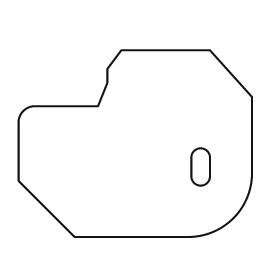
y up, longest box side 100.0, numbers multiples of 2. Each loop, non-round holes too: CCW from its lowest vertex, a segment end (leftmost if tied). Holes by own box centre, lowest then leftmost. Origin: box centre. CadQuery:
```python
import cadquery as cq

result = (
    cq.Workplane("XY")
    .moveTo(-26.0, -40.0)
    .lineTo(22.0, -40.0)
    .threePointArc((42.0, -32.0), (50.0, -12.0))
    .lineTo(50.0, 20.0)
    .lineTo(32.0, 40.0)
    .lineTo(-6.0, 40.0)
    .lineTo(-12.0, 32.0)
    .lineTo(-12.0, 26.0)
    .lineTo(-16.0, 16.0)
    .lineTo(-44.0, 16.0)
    .threePointArc((-48.0, 14.0), (-50.0, 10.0))
    .lineTo(-50.0, -16.0)
    .close()
    .moveTo(24.0, -14.0)
    .threePointArc((28.0, -18.0), (32.0, -14.0))
    .lineTo(32.0, -6.0)
    .threePointArc((28.0, -2.0), (24.0, -6.0))
    .close()
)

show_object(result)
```